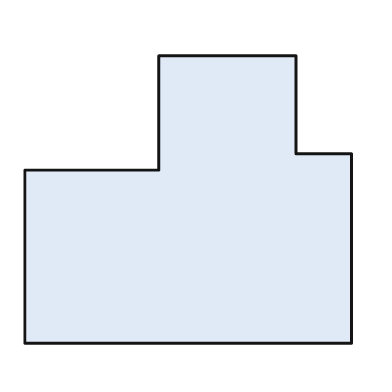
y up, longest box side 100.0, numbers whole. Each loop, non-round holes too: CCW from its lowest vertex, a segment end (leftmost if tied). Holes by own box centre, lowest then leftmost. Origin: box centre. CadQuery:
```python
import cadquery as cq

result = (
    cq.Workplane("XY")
    .moveTo(-50.0, -44.0)
    .lineTo(50.0, -44.0)
    .lineTo(50.0, 14.0)
    .lineTo(33.0, 14.0)
    .lineTo(33.0, 44.0)
    .lineTo(-9.0, 44.0)
    .lineTo(-9.0, 9.0)
    .lineTo(-50.0, 9.0)
    .close()
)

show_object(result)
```